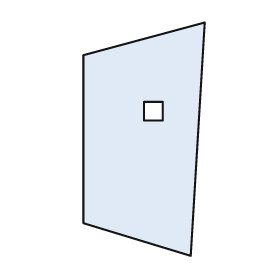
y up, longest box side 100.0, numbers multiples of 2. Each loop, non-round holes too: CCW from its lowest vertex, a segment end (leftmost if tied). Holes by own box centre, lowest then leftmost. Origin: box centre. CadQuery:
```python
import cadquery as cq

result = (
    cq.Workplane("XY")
    .moveTo(20.0, -50.0)
    .lineTo(26.0, 50.0)
    .lineTo(-26.0, 36.0)
    .lineTo(-26.0, -36.0)
    .close()
    .moveTo(0.0, 8.0)
    .lineTo(8.0, 8.0)
    .lineTo(8.0, 16.0)
    .lineTo(0.0, 16.0)
    .close()
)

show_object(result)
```